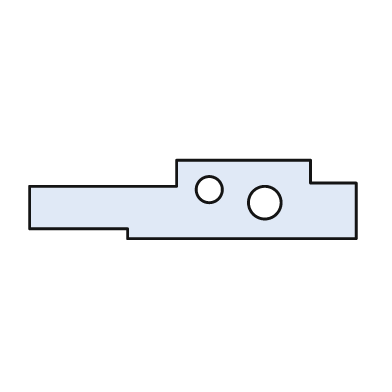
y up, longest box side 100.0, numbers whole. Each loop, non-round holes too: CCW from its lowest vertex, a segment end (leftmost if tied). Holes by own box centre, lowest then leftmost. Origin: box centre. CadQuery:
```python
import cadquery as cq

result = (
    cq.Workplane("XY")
    .moveTo(-20.0, -12.0)
    .lineTo(50.0, -12.0)
    .lineTo(50.0, 5.0)
    .lineTo(36.0, 5.0)
    .lineTo(36.0, 12.0)
    .lineTo(-5.0, 12.0)
    .lineTo(-5.0, 4.0)
    .lineTo(-50.0, 4.0)
    .lineTo(-50.0, -9.0)
    .lineTo(-20.0, -9.0)
    .close()
    .moveTo(22.0, -1.0)
    .circle(5.0)
    .moveTo(5.0, 3.0)
    .circle(4.0)
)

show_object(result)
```